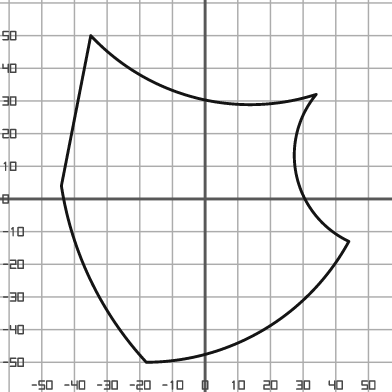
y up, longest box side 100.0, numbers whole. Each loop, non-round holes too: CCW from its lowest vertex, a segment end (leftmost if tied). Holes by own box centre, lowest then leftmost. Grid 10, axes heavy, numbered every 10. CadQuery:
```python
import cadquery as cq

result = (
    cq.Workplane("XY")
    .moveTo(-18.0, -50.0)
    .threePointArc((18.0, -40.0), (44.0, -13.0))
    .threePointArc((28.0, 7.0), (34.0, 32.0))
    .threePointArc((-3.0, 31.0), (-35.0, 50.0))
    .lineTo(-44.0, 4.0)
    .threePointArc((-35.0, -25.0), (-18.0, -50.0))
    .close()
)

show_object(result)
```